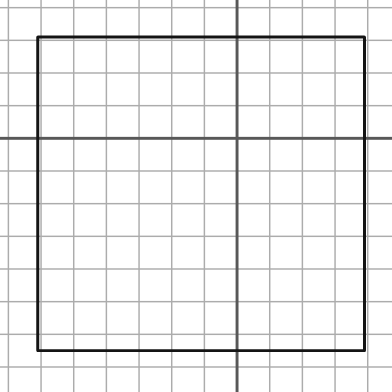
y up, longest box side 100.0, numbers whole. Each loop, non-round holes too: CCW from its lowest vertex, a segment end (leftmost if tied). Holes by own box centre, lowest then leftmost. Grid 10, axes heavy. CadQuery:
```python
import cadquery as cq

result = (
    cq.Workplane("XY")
    .moveTo(-61.0, -65.0)
    .lineTo(39.0, -65.0)
    .lineTo(39.0, 31.0)
    .lineTo(-61.0, 31.0)
    .close()
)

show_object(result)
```